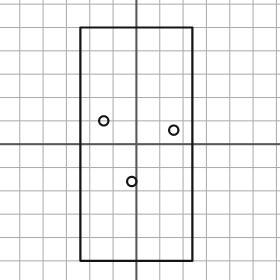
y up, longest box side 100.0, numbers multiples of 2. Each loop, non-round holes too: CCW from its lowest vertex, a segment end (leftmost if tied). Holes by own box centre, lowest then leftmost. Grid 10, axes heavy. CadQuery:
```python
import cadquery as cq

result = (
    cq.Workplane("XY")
    .moveTo(-24.0, -50.0)
    .lineTo(24.0, -50.0)
    .lineTo(24.0, 50.0)
    .lineTo(-24.0, 50.0)
    .close()
    .moveTo(-2.0, -16.0)
    .circle(2.0)
    .moveTo(16.0, 6.0)
    .circle(2.0)
    .moveTo(-14.0, 10.0)
    .circle(2.0)
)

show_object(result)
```